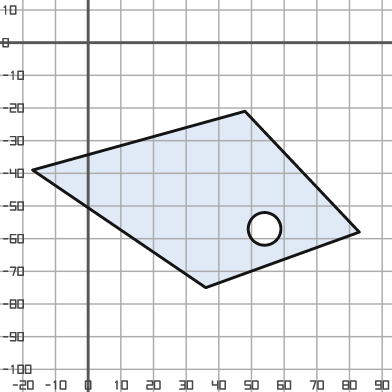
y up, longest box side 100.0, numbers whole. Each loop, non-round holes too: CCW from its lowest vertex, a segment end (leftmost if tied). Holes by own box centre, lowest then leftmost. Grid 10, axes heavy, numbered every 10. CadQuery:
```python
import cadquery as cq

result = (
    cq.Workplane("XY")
    .moveTo(36.0, -75.0)
    .lineTo(83.0, -58.0)
    .lineTo(48.0, -21.0)
    .lineTo(-17.0, -39.0)
    .close()
    .moveTo(54.0, -57.0)
    .circle(5.0)
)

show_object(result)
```